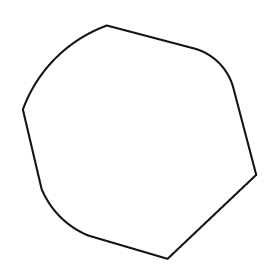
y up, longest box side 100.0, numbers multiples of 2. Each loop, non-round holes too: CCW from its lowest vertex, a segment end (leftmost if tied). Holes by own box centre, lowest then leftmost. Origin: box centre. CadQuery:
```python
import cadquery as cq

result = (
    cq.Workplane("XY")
    .moveTo(12.0, -50.0)
    .lineTo(50.0, -14.0)
    .lineTo(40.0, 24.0)
    .threePointArc((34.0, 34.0), (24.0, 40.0))
    .lineTo(-14.0, 50.0)
    .threePointArc((-36.0, 36.0), (-50.0, 14.0))
    .lineTo(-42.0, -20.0)
    .threePointArc((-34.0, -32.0), (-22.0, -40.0))
    .close()
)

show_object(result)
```